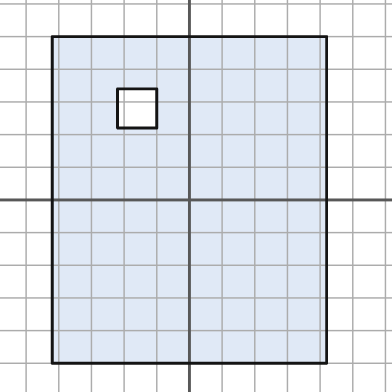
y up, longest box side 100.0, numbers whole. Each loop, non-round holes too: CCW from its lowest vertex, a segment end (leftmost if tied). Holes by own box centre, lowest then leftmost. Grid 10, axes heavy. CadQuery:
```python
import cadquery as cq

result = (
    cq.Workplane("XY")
    .moveTo(-42.0, -50.0)
    .lineTo(42.0, -50.0)
    .lineTo(42.0, 50.0)
    .lineTo(-42.0, 50.0)
    .close()
    .moveTo(-22.0, 22.0)
    .lineTo(-10.0, 22.0)
    .lineTo(-10.0, 34.0)
    .lineTo(-22.0, 34.0)
    .close()
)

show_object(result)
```